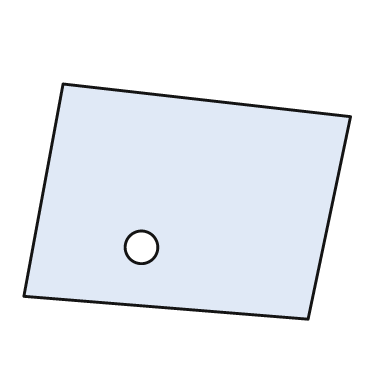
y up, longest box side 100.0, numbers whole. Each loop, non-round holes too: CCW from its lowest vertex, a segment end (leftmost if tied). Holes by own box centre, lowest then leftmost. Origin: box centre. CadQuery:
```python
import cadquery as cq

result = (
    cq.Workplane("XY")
    .moveTo(37.0, -36.0)
    .lineTo(50.0, 26.0)
    .lineTo(-38.0, 36.0)
    .lineTo(-50.0, -29.0)
    .close()
    .moveTo(-14.0, -14.0)
    .circle(5.0)
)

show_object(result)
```